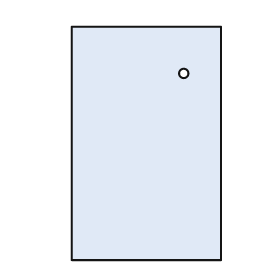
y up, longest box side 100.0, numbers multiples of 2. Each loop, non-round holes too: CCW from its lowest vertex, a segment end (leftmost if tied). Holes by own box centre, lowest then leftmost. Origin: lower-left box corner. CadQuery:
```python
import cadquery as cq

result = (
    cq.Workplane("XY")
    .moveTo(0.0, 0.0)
    .lineTo(64.0, 0.0)
    .lineTo(64.0, 100.0)
    .lineTo(0.0, 100.0)
    .close()
    .moveTo(48.0, 80.0)
    .circle(2.0)
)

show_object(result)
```